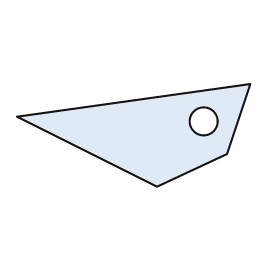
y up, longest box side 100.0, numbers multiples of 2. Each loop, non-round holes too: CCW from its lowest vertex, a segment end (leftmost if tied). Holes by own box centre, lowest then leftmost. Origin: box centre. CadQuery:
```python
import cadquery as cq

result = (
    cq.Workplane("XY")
    .moveTo(10.0, -22.0)
    .lineTo(40.0, -8.0)
    .lineTo(50.0, 22.0)
    .lineTo(-50.0, 8.0)
    .close()
    .moveTo(30.0, 6.0)
    .circle(6.0)
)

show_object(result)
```